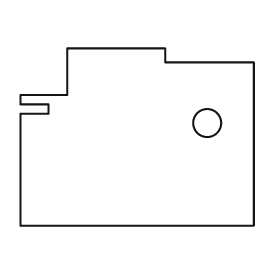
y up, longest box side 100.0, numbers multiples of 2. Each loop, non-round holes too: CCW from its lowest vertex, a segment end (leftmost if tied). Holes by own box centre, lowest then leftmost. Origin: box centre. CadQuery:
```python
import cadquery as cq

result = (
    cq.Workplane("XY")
    .moveTo(-50.0, -38.0)
    .lineTo(50.0, -38.0)
    .lineTo(50.0, 32.0)
    .lineTo(12.0, 32.0)
    .lineTo(12.0, 38.0)
    .lineTo(-30.0, 38.0)
    .lineTo(-30.0, 18.0)
    .lineTo(-50.0, 18.0)
    .lineTo(-50.0, 14.0)
    .lineTo(-38.0, 14.0)
    .lineTo(-38.0, 10.0)
    .lineTo(-50.0, 10.0)
    .close()
    .moveTo(30.0, 6.0)
    .circle(6.0)
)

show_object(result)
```